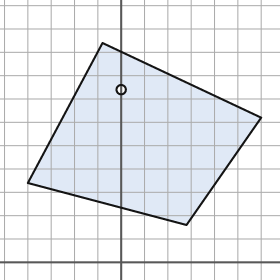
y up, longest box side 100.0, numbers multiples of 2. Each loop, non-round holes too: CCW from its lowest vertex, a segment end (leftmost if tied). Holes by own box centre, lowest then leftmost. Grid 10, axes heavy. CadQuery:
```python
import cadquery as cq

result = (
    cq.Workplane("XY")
    .moveTo(28.0, 16.0)
    .lineTo(60.0, 62.0)
    .lineTo(-8.0, 94.0)
    .lineTo(-40.0, 34.0)
    .close()
    .moveTo(0.0, 74.0)
    .circle(2.0)
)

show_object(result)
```